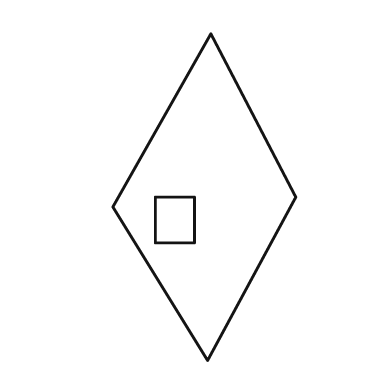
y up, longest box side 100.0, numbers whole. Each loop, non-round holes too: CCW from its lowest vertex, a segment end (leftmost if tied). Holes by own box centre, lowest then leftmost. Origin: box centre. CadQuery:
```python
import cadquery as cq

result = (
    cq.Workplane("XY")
    .moveTo(1.0, -50.0)
    .lineTo(28.0, 0.0)
    .lineTo(2.0, 50.0)
    .lineTo(-28.0, -3.0)
    .close()
    .moveTo(-15.0, -14.0)
    .lineTo(-3.0, -14.0)
    .lineTo(-3.0, 0.0)
    .lineTo(-15.0, 0.0)
    .close()
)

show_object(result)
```